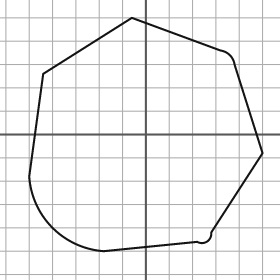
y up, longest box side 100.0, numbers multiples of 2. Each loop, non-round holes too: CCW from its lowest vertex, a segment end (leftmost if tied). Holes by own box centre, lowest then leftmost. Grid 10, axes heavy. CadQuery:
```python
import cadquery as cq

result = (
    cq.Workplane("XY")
    .moveTo(-18.0, -50.0)
    .lineTo(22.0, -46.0)
    .threePointArc((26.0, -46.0), (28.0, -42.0))
    .lineTo(50.0, -8.0)
    .lineTo(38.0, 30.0)
    .threePointArc((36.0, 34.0), (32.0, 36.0))
    .lineTo(-6.0, 50.0)
    .lineTo(-44.0, 26.0)
    .lineTo(-50.0, -18.0)
    .threePointArc((-40.0, -40.0), (-18.0, -50.0))
    .close()
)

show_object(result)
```